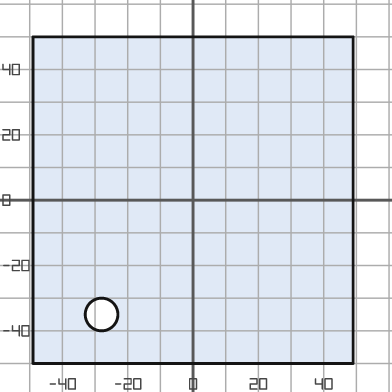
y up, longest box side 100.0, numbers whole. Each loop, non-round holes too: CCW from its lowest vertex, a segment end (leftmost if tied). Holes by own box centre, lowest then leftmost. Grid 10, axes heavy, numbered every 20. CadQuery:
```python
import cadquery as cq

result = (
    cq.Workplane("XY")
    .moveTo(-49.0, -50.0)
    .lineTo(49.0, -50.0)
    .lineTo(49.0, 50.0)
    .lineTo(-49.0, 50.0)
    .close()
    .moveTo(-28.0, -35.0)
    .circle(5.0)
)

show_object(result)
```